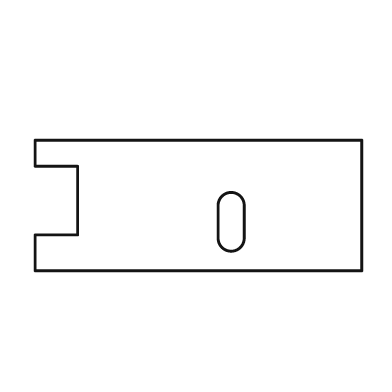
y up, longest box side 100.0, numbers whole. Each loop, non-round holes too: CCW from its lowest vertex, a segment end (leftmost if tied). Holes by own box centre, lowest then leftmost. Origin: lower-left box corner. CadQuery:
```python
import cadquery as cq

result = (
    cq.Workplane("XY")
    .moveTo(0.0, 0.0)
    .lineTo(100.0, 0.0)
    .lineTo(100.0, 40.0)
    .lineTo(0.0, 40.0)
    .lineTo(0.0, 32.0)
    .lineTo(13.0, 32.0)
    .lineTo(13.0, 11.0)
    .lineTo(0.0, 11.0)
    .close()
    .moveTo(56.0, 10.0)
    .threePointArc((60.0, 6.0), (64.0, 10.0))
    .lineTo(64.0, 20.0)
    .threePointArc((60.0, 24.0), (56.0, 20.0))
    .close()
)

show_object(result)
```